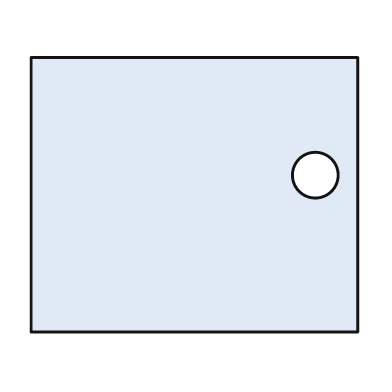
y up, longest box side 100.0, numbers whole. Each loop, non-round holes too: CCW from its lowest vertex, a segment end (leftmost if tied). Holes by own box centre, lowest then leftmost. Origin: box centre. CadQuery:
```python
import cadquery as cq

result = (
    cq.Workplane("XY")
    .moveTo(-50.0, -42.0)
    .lineTo(50.0, -42.0)
    .lineTo(50.0, 42.0)
    .lineTo(-50.0, 42.0)
    .close()
    .moveTo(37.0, 6.0)
    .circle(7.0)
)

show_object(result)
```